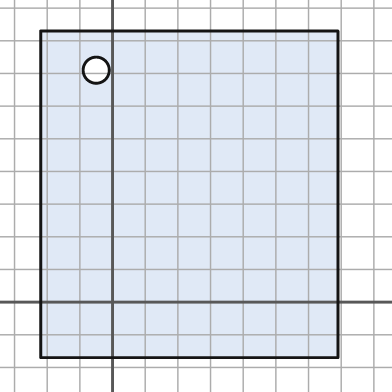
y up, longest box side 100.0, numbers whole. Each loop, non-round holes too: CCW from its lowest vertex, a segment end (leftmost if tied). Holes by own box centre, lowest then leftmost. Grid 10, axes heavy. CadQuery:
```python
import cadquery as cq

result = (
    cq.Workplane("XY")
    .moveTo(-22.0, -17.0)
    .lineTo(69.0, -17.0)
    .lineTo(69.0, 83.0)
    .lineTo(-22.0, 83.0)
    .close()
    .moveTo(-5.0, 71.0)
    .circle(4.0)
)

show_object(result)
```